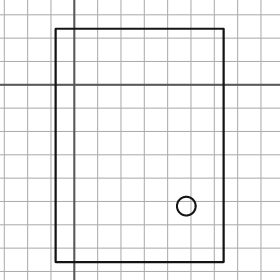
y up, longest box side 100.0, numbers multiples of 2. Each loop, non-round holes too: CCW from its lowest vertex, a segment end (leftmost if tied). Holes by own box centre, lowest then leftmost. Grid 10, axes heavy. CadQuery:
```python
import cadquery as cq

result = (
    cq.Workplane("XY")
    .moveTo(-8.0, -76.0)
    .lineTo(64.0, -76.0)
    .lineTo(64.0, 24.0)
    .lineTo(-8.0, 24.0)
    .close()
    .moveTo(48.0, -52.0)
    .circle(4.0)
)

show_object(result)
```